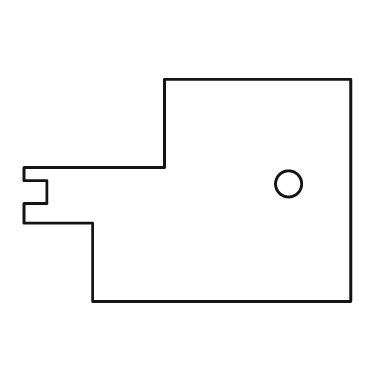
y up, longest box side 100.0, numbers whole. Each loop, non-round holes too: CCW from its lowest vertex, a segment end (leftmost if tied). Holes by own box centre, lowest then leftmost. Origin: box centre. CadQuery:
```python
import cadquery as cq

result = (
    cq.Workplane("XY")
    .moveTo(-29.0, -34.0)
    .lineTo(50.0, -34.0)
    .lineTo(50.0, 34.0)
    .lineTo(-7.0, 34.0)
    .lineTo(-7.0, 7.0)
    .lineTo(-50.0, 7.0)
    .lineTo(-50.0, 3.0)
    .lineTo(-43.0, 3.0)
    .lineTo(-43.0, -4.0)
    .lineTo(-50.0, -4.0)
    .lineTo(-50.0, -10.0)
    .lineTo(-29.0, -10.0)
    .close()
    .moveTo(31.0, 2.0)
    .circle(4.0)
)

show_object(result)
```